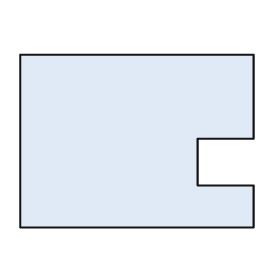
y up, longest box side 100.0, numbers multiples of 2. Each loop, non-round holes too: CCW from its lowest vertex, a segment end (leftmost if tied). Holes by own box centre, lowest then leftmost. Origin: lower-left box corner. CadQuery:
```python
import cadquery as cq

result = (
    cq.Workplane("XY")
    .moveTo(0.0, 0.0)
    .lineTo(100.0, 0.0)
    .lineTo(100.0, 18.0)
    .lineTo(76.0, 18.0)
    .lineTo(76.0, 38.0)
    .lineTo(100.0, 38.0)
    .lineTo(100.0, 74.0)
    .lineTo(0.0, 74.0)
    .close()
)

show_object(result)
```